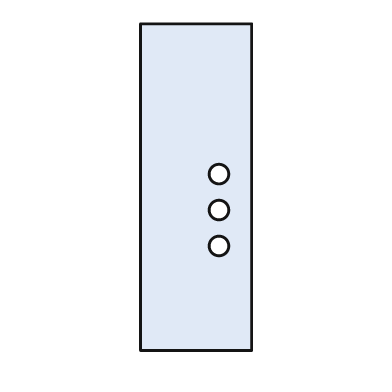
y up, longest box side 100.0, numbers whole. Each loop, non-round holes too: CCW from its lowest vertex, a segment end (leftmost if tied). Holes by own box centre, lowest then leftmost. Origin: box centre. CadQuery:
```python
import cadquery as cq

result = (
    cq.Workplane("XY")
    .moveTo(-17.0, -50.0)
    .lineTo(17.0, -50.0)
    .lineTo(17.0, 50.0)
    .lineTo(-17.0, 50.0)
    .close()
    .moveTo(7.0, -18.0)
    .circle(3.0)
    .moveTo(7.0, -7.0)
    .circle(3.0)
    .moveTo(7.0, 4.0)
    .circle(3.0)
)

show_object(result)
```